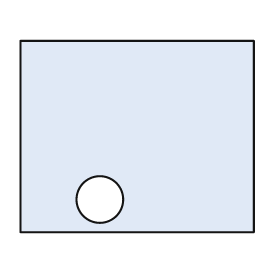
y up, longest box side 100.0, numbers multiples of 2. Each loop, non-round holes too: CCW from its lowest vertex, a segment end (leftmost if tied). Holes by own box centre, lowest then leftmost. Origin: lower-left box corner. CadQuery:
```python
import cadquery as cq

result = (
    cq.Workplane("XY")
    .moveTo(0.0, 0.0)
    .lineTo(100.0, 0.0)
    .lineTo(100.0, 82.0)
    .lineTo(0.0, 82.0)
    .close()
    .moveTo(34.0, 14.0)
    .circle(10.0)
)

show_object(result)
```